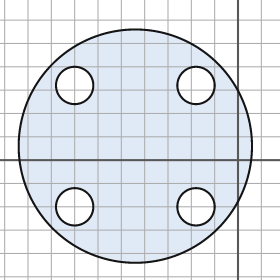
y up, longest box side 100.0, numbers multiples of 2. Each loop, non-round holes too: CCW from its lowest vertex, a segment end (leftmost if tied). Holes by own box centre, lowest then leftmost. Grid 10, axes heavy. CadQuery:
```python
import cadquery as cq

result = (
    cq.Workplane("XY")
    .moveTo(-44.0, 6.0)
    .circle(50.0)
    .moveTo(-70.0, -20.0)
    .circle(8.0)
    .moveTo(-18.0, -20.0)
    .circle(8.0)
    .moveTo(-70.0, 32.0)
    .circle(8.0)
    .moveTo(-18.0, 32.0)
    .circle(8.0)
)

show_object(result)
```